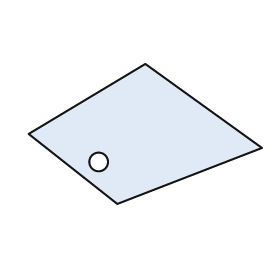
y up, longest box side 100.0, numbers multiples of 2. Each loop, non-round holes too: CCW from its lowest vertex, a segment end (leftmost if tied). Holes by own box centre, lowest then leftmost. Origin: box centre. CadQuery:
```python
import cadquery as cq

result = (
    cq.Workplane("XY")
    .moveTo(-12.0, -30.0)
    .lineTo(50.0, -6.0)
    .lineTo(0.0, 30.0)
    .lineTo(-50.0, 0.0)
    .close()
    .moveTo(-20.0, -12.0)
    .circle(4.0)
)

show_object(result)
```